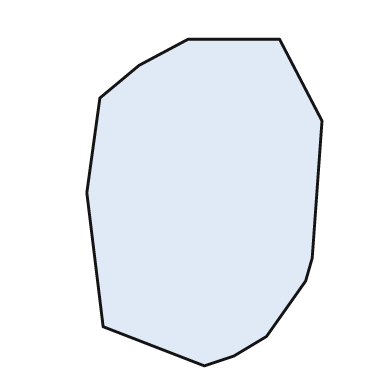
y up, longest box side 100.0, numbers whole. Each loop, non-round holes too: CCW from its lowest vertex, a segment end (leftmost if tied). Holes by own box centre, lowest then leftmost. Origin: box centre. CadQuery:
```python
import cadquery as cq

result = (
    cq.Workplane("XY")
    .moveTo(0.0, -50.0)
    .lineTo(9.0, -47.0)
    .lineTo(19.0, -41.0)
    .lineTo(31.0, -24.0)
    .lineTo(33.0, -17.0)
    .lineTo(36.0, 25.0)
    .lineTo(23.0, 50.0)
    .lineTo(-5.0, 50.0)
    .lineTo(-20.0, 42.0)
    .lineTo(-32.0, 32.0)
    .lineTo(-36.0, 3.0)
    .lineTo(-31.0, -38.0)
    .close()
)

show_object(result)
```